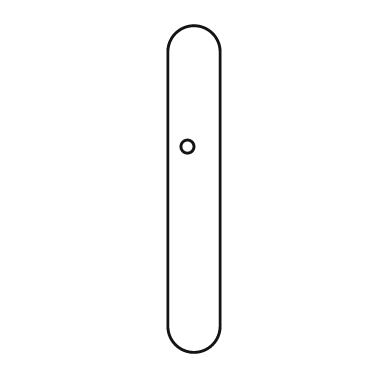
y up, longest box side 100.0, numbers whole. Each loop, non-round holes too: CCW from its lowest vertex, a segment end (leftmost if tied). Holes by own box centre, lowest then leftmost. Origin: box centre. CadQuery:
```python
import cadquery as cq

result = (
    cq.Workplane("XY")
    .moveTo(-8.0, -42.0)
    .threePointArc((0.0, -50.0), (8.0, -42.0))
    .lineTo(8.0, 42.0)
    .threePointArc((0.0, 50.0), (-8.0, 42.0))
    .close()
    .moveTo(-2.0, 13.0)
    .circle(2.0)
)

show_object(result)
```